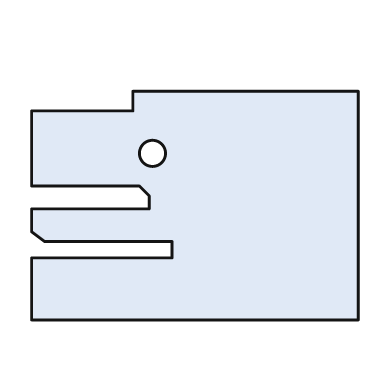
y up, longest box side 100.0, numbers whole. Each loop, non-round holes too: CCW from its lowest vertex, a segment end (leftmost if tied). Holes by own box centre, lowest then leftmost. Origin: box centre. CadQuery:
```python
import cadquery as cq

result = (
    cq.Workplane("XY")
    .moveTo(-50.0, -35.0)
    .lineTo(50.0, -35.0)
    .lineTo(50.0, 35.0)
    .lineTo(-19.0, 35.0)
    .lineTo(-19.0, 29.0)
    .lineTo(-50.0, 29.0)
    .lineTo(-50.0, 6.0)
    .lineTo(-17.0, 6.0)
    .lineTo(-14.0, 3.0)
    .lineTo(-14.0, -1.0)
    .lineTo(-50.0, -1.0)
    .lineTo(-50.0, -8.0)
    .lineTo(-46.0, -11.0)
    .lineTo(-7.0, -11.0)
    .lineTo(-7.0, -16.0)
    .lineTo(-50.0, -16.0)
    .close()
    .moveTo(-13.0, 16.0)
    .circle(4.0)
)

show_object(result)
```